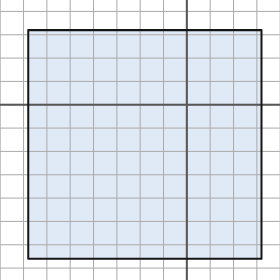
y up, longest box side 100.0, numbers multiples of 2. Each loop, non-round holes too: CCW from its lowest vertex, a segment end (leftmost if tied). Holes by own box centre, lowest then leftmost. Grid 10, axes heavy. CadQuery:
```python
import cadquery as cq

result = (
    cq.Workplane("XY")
    .moveTo(-68.0, -66.0)
    .lineTo(32.0, -66.0)
    .lineTo(32.0, 32.0)
    .lineTo(-68.0, 32.0)
    .close()
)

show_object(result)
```